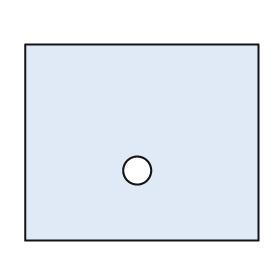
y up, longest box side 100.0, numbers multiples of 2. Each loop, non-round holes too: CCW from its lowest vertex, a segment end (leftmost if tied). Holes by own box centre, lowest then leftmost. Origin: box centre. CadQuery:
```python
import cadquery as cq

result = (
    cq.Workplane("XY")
    .moveTo(-50.0, -42.0)
    .lineTo(50.0, -42.0)
    .lineTo(50.0, 42.0)
    .lineTo(-50.0, 42.0)
    .close()
    .moveTo(-2.0, -12.0)
    .circle(6.0)
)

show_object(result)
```